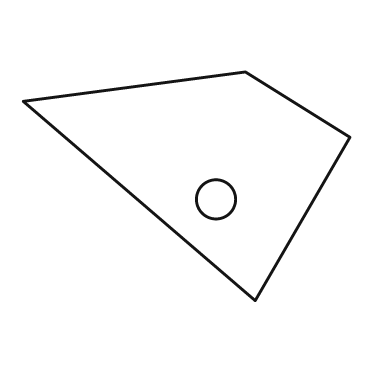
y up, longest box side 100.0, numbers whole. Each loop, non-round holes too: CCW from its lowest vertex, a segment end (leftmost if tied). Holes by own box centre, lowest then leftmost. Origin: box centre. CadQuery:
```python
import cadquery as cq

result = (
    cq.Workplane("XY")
    .moveTo(21.0, -35.0)
    .lineTo(50.0, 15.0)
    .lineTo(18.0, 35.0)
    .lineTo(-50.0, 26.0)
    .close()
    .moveTo(9.0, -4.0)
    .circle(6.0)
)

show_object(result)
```